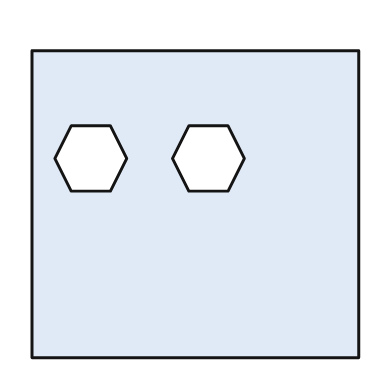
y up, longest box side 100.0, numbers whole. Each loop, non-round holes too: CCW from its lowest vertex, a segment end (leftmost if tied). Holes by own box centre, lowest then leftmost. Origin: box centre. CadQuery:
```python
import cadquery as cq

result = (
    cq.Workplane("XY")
    .moveTo(-50.0, -47.0)
    .lineTo(50.0, -47.0)
    .lineTo(50.0, 47.0)
    .lineTo(-50.0, 47.0)
    .close()
    .moveTo(-38.0, 4.0)
    .lineTo(-26.0, 4.0)
    .lineTo(-21.0, 14.0)
    .lineTo(-26.0, 24.0)
    .lineTo(-38.0, 24.0)
    .lineTo(-43.0, 14.0)
    .close()
    .moveTo(-2.0, 4.0)
    .lineTo(10.0, 4.0)
    .lineTo(15.0, 14.0)
    .lineTo(10.0, 24.0)
    .lineTo(-2.0, 24.0)
    .lineTo(-7.0, 14.0)
    .close()
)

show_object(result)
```